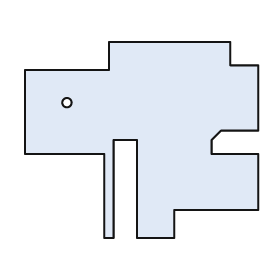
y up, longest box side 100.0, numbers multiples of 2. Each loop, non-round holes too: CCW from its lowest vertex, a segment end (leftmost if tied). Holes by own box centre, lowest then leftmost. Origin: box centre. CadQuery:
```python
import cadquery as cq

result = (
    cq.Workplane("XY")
    .moveTo(-16.0, -42.0)
    .lineTo(-12.0, -42.0)
    .lineTo(-12.0, 0.0)
    .lineTo(-2.0, 0.0)
    .lineTo(-2.0, -42.0)
    .lineTo(14.0, -42.0)
    .lineTo(14.0, -30.0)
    .lineTo(50.0, -30.0)
    .lineTo(50.0, -6.0)
    .lineTo(30.0, -6.0)
    .lineTo(30.0, 0.0)
    .lineTo(34.0, 4.0)
    .lineTo(50.0, 4.0)
    .lineTo(50.0, 32.0)
    .lineTo(38.0, 32.0)
    .lineTo(38.0, 42.0)
    .lineTo(-14.0, 42.0)
    .lineTo(-14.0, 30.0)
    .lineTo(-50.0, 30.0)
    .lineTo(-50.0, -6.0)
    .lineTo(-16.0, -6.0)
    .close()
    .moveTo(-32.0, 16.0)
    .circle(2.0)
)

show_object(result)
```